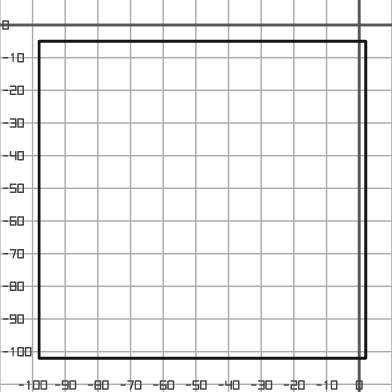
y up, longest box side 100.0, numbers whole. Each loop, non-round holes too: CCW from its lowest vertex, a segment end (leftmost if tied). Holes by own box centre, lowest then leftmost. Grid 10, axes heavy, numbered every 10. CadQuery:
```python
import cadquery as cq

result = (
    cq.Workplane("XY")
    .moveTo(-98.0, -102.0)
    .lineTo(2.0, -102.0)
    .lineTo(2.0, -5.0)
    .lineTo(-98.0, -5.0)
    .close()
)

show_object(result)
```